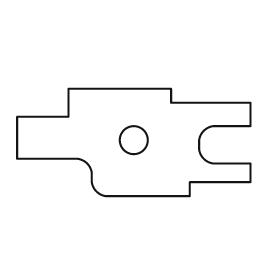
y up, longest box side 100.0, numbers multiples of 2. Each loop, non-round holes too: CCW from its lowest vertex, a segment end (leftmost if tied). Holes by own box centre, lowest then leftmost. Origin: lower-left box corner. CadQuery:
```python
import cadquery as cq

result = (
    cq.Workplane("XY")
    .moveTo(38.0, 0.0)
    .lineTo(74.0, 0.0)
    .lineTo(74.0, 6.0)
    .lineTo(100.0, 6.0)
    .lineTo(100.0, 14.0)
    .lineTo(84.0, 14.0)
    .threePointArc((80.0, 16.0), (78.0, 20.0))
    .lineTo(78.0, 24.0)
    .threePointArc((80.0, 28.0), (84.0, 30.0))
    .lineTo(100.0, 30.0)
    .lineTo(100.0, 40.0)
    .lineTo(66.0, 40.0)
    .lineTo(66.0, 46.0)
    .lineTo(22.0, 46.0)
    .lineTo(22.0, 34.0)
    .lineTo(0.0, 34.0)
    .lineTo(0.0, 16.0)
    .lineTo(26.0, 16.0)
    .threePointArc((30.0, 14.0), (32.0, 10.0))
    .lineTo(32.0, 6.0)
    .threePointArc((34.0, 2.0), (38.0, 0.0))
    .close()
    .moveTo(50.0, 24.0)
    .circle(6.0)
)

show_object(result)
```